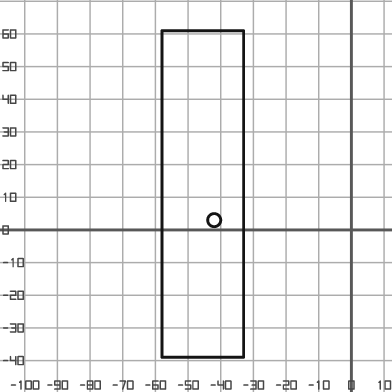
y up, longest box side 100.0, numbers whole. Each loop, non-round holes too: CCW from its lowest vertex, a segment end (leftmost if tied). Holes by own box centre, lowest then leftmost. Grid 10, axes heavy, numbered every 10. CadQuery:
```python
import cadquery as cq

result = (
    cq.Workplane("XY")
    .moveTo(-58.0, -39.0)
    .lineTo(-33.0, -39.0)
    .lineTo(-33.0, 61.0)
    .lineTo(-58.0, 61.0)
    .close()
    .moveTo(-42.0, 3.0)
    .circle(2.0)
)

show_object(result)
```